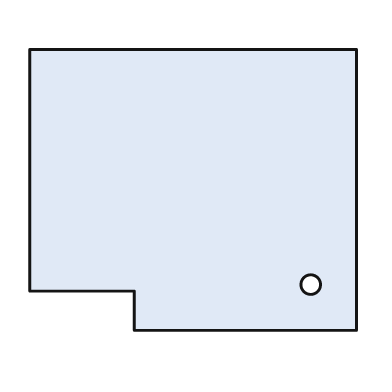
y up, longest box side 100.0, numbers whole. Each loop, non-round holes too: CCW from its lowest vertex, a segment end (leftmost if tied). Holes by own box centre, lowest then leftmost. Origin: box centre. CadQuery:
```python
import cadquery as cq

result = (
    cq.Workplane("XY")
    .moveTo(-18.0, -43.0)
    .lineTo(50.0, -43.0)
    .lineTo(50.0, 43.0)
    .lineTo(-50.0, 43.0)
    .lineTo(-50.0, -31.0)
    .lineTo(-18.0, -31.0)
    .close()
    .moveTo(36.0, -29.0)
    .circle(3.0)
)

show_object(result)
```